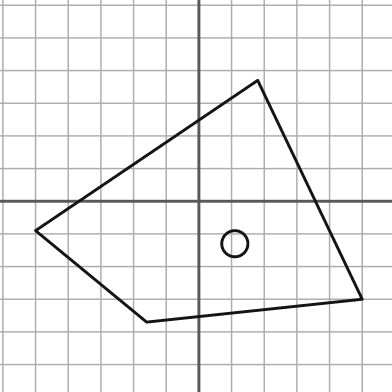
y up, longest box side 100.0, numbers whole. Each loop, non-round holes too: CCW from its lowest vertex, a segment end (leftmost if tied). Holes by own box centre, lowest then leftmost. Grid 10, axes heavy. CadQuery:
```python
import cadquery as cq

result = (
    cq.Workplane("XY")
    .moveTo(-16.0, -37.0)
    .lineTo(50.0, -30.0)
    .lineTo(18.0, 37.0)
    .lineTo(-50.0, -9.0)
    .close()
    .moveTo(11.0, -13.0)
    .circle(4.0)
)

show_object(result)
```